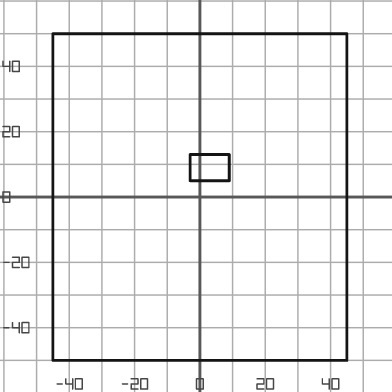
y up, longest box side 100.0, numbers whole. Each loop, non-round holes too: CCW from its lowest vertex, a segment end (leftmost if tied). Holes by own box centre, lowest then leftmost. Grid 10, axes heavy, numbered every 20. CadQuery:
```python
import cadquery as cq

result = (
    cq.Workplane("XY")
    .moveTo(-45.0, -50.0)
    .lineTo(45.0, -50.0)
    .lineTo(45.0, 50.0)
    .lineTo(-45.0, 50.0)
    .close()
    .moveTo(-3.0, 5.0)
    .lineTo(9.0, 5.0)
    .lineTo(9.0, 13.0)
    .lineTo(-3.0, 13.0)
    .close()
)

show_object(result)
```